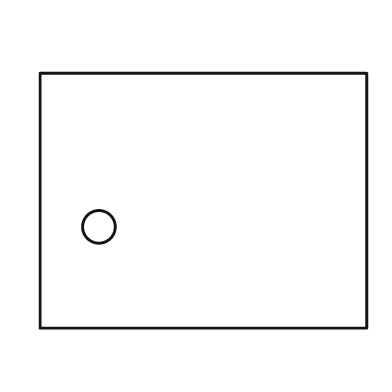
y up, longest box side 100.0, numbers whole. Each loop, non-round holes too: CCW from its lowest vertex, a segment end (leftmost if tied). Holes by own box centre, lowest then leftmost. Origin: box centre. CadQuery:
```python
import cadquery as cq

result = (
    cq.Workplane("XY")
    .moveTo(-50.0, -39.0)
    .lineTo(50.0, -39.0)
    .lineTo(50.0, 39.0)
    .lineTo(-50.0, 39.0)
    .close()
    .moveTo(-32.0, -8.0)
    .circle(5.0)
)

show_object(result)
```